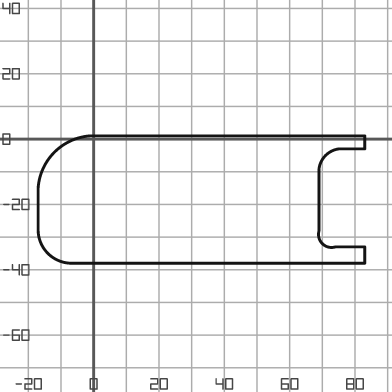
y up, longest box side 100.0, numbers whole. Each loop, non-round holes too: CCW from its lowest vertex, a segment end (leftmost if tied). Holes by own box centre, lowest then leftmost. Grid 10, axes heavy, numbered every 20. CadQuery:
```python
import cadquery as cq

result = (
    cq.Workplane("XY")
    .moveTo(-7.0, -38.0)
    .lineTo(83.0, -38.0)
    .lineTo(83.0, -33.0)
    .lineTo(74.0, -33.0)
    .threePointArc((70.0, -32.0), (69.0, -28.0))
    .lineTo(69.0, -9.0)
    .threePointArc((71.0, -5.0), (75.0, -3.0))
    .lineTo(83.0, -3.0)
    .lineTo(83.0, 1.0)
    .lineTo(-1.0, 1.0)
    .threePointArc((-12.0, -4.0), (-17.0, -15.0))
    .lineTo(-17.0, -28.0)
    .threePointArc((-14.0, -35.0), (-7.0, -38.0))
    .close()
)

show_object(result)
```